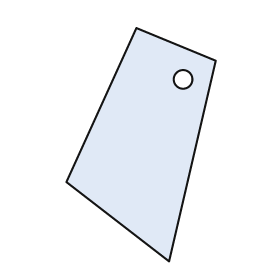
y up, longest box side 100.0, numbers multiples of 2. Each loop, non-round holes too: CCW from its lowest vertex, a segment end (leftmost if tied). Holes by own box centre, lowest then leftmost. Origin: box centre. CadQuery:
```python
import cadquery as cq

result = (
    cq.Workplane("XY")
    .moveTo(12.0, -50.0)
    .lineTo(32.0, 36.0)
    .lineTo(-2.0, 50.0)
    .lineTo(-32.0, -16.0)
    .close()
    .moveTo(18.0, 28.0)
    .circle(4.0)
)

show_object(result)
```